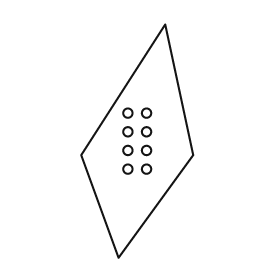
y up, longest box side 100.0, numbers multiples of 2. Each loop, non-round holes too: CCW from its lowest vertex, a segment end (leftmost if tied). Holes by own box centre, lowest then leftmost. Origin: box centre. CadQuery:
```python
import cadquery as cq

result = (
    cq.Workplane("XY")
    .moveTo(-8.0, -50.0)
    .lineTo(24.0, -6.0)
    .lineTo(12.0, 50.0)
    .lineTo(-24.0, -6.0)
    .close()
    .moveTo(-4.0, -12.0)
    .circle(2.0)
    .moveTo(4.0, -12.0)
    .circle(2.0)
    .moveTo(-4.0, -4.0)
    .circle(2.0)
    .moveTo(4.0, -4.0)
    .circle(2.0)
    .moveTo(-4.0, 4.0)
    .circle(2.0)
    .moveTo(4.0, 4.0)
    .circle(2.0)
    .moveTo(-4.0, 12.0)
    .circle(2.0)
    .moveTo(4.0, 12.0)
    .circle(2.0)
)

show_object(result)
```